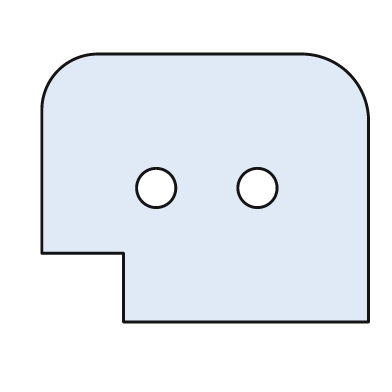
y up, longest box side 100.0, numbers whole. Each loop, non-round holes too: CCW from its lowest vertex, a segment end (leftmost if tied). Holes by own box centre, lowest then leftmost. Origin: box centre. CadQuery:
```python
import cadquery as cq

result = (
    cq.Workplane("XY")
    .moveTo(-25.0, -41.0)
    .lineTo(50.0, -41.0)
    .lineTo(50.0, 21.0)
    .threePointArc((44.0, 35.0), (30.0, 41.0))
    .lineTo(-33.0, 41.0)
    .threePointArc((-45.0, 36.0), (-50.0, 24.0))
    .lineTo(-50.0, -20.0)
    .lineTo(-25.0, -20.0)
    .close()
    .moveTo(-15.0, 0.0)
    .circle(6.0)
    .moveTo(16.0, 0.0)
    .circle(6.0)
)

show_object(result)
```